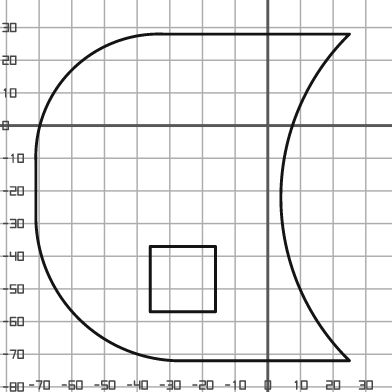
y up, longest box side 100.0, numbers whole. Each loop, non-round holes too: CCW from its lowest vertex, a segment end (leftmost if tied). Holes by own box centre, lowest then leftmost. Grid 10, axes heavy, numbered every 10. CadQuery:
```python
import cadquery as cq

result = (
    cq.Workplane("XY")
    .moveTo(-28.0, -72.0)
    .lineTo(25.0, -72.0)
    .threePointArc((4.0, -22.0), (25.0, 28.0))
    .lineTo(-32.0, 28.0)
    .threePointArc((-60.0, 17.0), (-71.0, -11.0))
    .lineTo(-71.0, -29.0)
    .threePointArc((-58.0, -59.0), (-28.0, -72.0))
    .close()
    .moveTo(-36.0, -57.0)
    .lineTo(-16.0, -57.0)
    .lineTo(-16.0, -37.0)
    .lineTo(-36.0, -37.0)
    .close()
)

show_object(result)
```